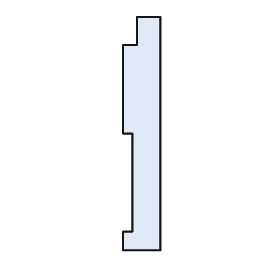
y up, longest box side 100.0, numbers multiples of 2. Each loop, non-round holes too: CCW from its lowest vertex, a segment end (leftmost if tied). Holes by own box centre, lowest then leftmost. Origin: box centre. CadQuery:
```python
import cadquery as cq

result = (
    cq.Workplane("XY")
    .moveTo(-8.0, -50.0)
    .lineTo(8.0, -50.0)
    .lineTo(8.0, 50.0)
    .lineTo(-2.0, 50.0)
    .lineTo(-2.0, 38.0)
    .lineTo(-8.0, 38.0)
    .lineTo(-8.0, 0.0)
    .lineTo(-4.0, 0.0)
    .lineTo(-4.0, -42.0)
    .lineTo(-8.0, -42.0)
    .close()
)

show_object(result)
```